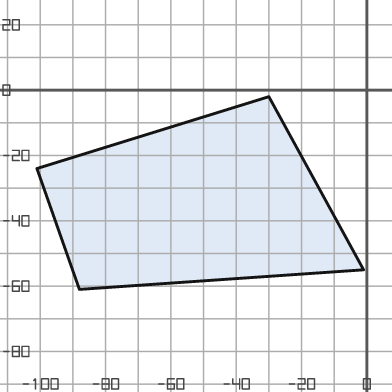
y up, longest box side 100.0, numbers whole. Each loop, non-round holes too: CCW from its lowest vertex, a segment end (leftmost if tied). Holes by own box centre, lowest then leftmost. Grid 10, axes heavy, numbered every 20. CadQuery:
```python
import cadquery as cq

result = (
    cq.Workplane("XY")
    .moveTo(-88.0, -61.0)
    .lineTo(-1.0, -55.0)
    .lineTo(-30.0, -2.0)
    .lineTo(-101.0, -24.0)
    .close()
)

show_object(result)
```